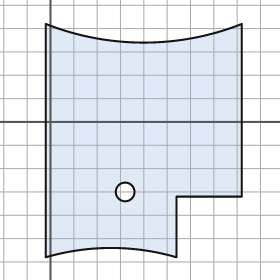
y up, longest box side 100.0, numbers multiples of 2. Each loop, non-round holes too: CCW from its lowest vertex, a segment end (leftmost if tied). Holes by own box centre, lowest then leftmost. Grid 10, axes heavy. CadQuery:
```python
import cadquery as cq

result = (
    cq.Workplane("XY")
    .moveTo(-2.0, -58.0)
    .threePointArc((26.0, -54.0), (54.0, -58.0))
    .lineTo(54.0, -32.0)
    .lineTo(82.0, -32.0)
    .lineTo(82.0, 42.0)
    .threePointArc((40.0, 34.0), (-2.0, 42.0))
    .close()
    .moveTo(32.0, -30.0)
    .circle(4.0)
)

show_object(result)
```